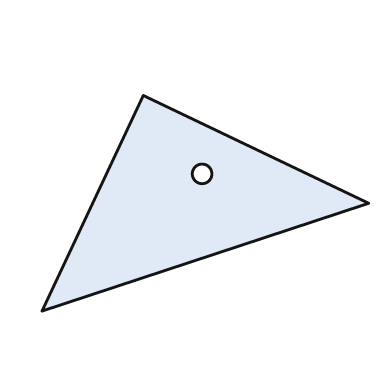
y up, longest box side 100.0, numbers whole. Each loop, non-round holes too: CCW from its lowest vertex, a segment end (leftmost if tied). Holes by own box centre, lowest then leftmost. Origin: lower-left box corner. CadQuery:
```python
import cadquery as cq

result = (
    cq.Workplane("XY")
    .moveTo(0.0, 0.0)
    .lineTo(100.0, 33.0)
    .lineTo(31.0, 66.0)
    .close()
    .moveTo(49.0, 42.0)
    .circle(3.0)
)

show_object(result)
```